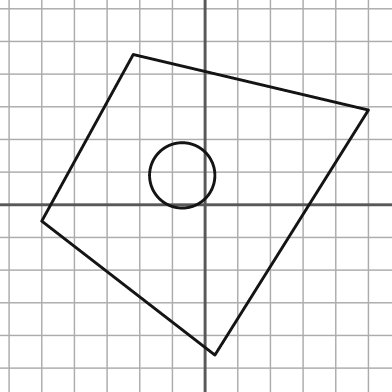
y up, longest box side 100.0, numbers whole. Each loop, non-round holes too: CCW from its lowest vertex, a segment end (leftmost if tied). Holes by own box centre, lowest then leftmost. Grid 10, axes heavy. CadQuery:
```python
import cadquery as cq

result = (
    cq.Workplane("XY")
    .moveTo(3.0, -46.0)
    .lineTo(50.0, 29.0)
    .lineTo(-22.0, 46.0)
    .lineTo(-50.0, -5.0)
    .close()
    .moveTo(-7.0, 9.0)
    .circle(10.0)
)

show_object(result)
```